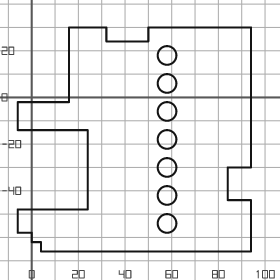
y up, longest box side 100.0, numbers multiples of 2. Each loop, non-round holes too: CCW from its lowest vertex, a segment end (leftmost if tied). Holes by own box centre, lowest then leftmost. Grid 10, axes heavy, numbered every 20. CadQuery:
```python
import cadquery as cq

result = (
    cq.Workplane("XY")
    .moveTo(4.0, -66.0)
    .lineTo(94.0, -66.0)
    .lineTo(94.0, -44.0)
    .lineTo(84.0, -44.0)
    .lineTo(84.0, -30.0)
    .lineTo(94.0, -30.0)
    .lineTo(94.0, 30.0)
    .lineTo(50.0, 30.0)
    .lineTo(50.0, 24.0)
    .lineTo(32.0, 24.0)
    .lineTo(32.0, 30.0)
    .lineTo(16.0, 30.0)
    .lineTo(16.0, -2.0)
    .lineTo(-6.0, -2.0)
    .lineTo(-6.0, -14.0)
    .lineTo(24.0, -14.0)
    .lineTo(24.0, -48.0)
    .lineTo(-6.0, -48.0)
    .lineTo(-6.0, -58.0)
    .lineTo(0.0, -58.0)
    .lineTo(0.0, -62.0)
    .lineTo(4.0, -62.0)
    .close()
    .moveTo(58.0, -54.0)
    .circle(4.0)
    .moveTo(58.0, -42.0)
    .circle(4.0)
    .moveTo(58.0, -30.0)
    .circle(4.0)
    .moveTo(58.0, -18.0)
    .circle(4.0)
    .moveTo(58.0, -6.0)
    .circle(4.0)
    .moveTo(58.0, 6.0)
    .circle(4.0)
    .moveTo(58.0, 18.0)
    .circle(4.0)
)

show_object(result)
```